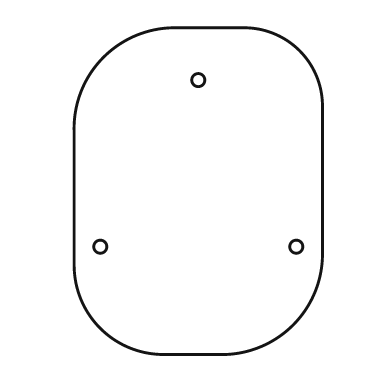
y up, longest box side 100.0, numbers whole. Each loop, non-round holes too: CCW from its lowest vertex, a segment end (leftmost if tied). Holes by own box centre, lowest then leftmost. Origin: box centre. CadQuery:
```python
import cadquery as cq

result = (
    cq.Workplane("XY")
    .moveTo(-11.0, -50.0)
    .lineTo(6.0, -50.0)
    .threePointArc((29.0, -41.0), (38.0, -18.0))
    .lineTo(38.0, 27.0)
    .threePointArc((31.0, 43.0), (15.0, 50.0))
    .lineTo(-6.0, 50.0)
    .threePointArc((-29.0, 41.0), (-38.0, 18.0))
    .lineTo(-38.0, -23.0)
    .threePointArc((-30.0, -42.0), (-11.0, -50.0))
    .close()
    .moveTo(-30.0, -17.0)
    .circle(2.0)
    .moveTo(30.0, -17.0)
    .circle(2.0)
    .moveTo(0.0, 34.0)
    .circle(2.0)
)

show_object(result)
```